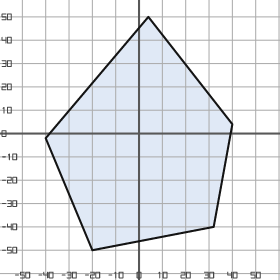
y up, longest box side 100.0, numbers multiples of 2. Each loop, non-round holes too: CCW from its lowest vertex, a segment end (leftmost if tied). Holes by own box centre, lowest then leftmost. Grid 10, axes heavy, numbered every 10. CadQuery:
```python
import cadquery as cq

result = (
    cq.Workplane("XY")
    .moveTo(-20.0, -50.0)
    .lineTo(32.0, -40.0)
    .lineTo(40.0, 4.0)
    .lineTo(4.0, 50.0)
    .lineTo(-40.0, -2.0)
    .close()
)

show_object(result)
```